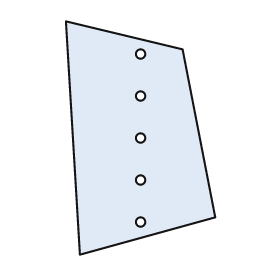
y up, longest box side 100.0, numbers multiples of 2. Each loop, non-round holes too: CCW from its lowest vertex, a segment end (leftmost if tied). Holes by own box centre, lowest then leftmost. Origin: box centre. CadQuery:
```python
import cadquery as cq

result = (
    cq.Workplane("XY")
    .moveTo(-26.0, -50.0)
    .lineTo(32.0, -34.0)
    .lineTo(18.0, 38.0)
    .lineTo(-32.0, 50.0)
    .close()
    .moveTo(0.0, -36.0)
    .circle(2.0)
    .moveTo(0.0, -18.0)
    .circle(2.0)
    .moveTo(0.0, 0.0)
    .circle(2.0)
    .moveTo(0.0, 18.0)
    .circle(2.0)
    .moveTo(0.0, 36.0)
    .circle(2.0)
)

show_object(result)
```